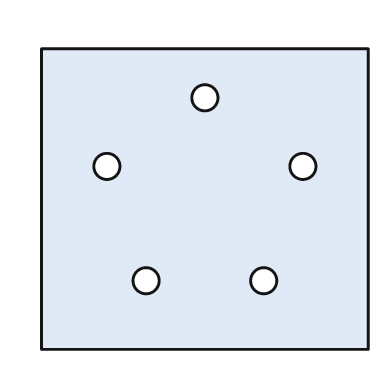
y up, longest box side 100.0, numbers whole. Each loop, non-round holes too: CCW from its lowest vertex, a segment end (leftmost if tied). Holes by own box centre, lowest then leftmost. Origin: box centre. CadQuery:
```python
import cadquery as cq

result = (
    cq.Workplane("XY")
    .moveTo(-50.0, -46.0)
    .lineTo(50.0, -46.0)
    .lineTo(50.0, 46.0)
    .lineTo(-50.0, 46.0)
    .close()
    .moveTo(-18.0, -25.0)
    .circle(4.0)
    .moveTo(18.0, -25.0)
    .circle(4.0)
    .moveTo(-30.0, 10.0)
    .circle(4.0)
    .moveTo(30.0, 10.0)
    .circle(4.0)
    .moveTo(0.0, 31.0)
    .circle(4.0)
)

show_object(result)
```